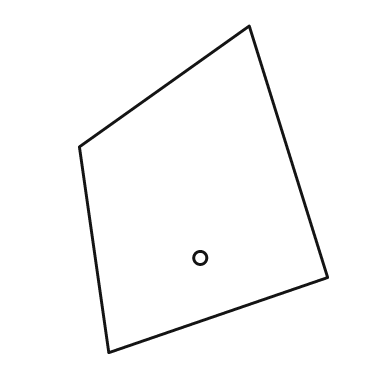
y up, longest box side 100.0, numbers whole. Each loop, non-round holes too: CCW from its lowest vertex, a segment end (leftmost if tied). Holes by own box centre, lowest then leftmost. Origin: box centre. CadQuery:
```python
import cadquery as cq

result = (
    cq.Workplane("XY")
    .moveTo(-29.0, -50.0)
    .lineTo(38.0, -27.0)
    .lineTo(14.0, 50.0)
    .lineTo(-38.0, 13.0)
    .close()
    .moveTo(-1.0, -21.0)
    .circle(2.0)
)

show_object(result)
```